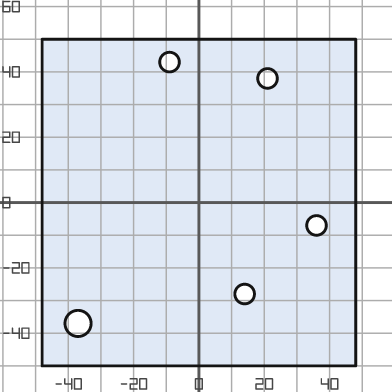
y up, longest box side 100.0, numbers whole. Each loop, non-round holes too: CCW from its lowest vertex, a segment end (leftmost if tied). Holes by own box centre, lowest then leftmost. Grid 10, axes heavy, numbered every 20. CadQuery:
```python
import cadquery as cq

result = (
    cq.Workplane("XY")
    .moveTo(-48.0, -50.0)
    .lineTo(48.0, -50.0)
    .lineTo(48.0, 50.0)
    .lineTo(-48.0, 50.0)
    .close()
    .moveTo(-37.0, -37.0)
    .circle(4.0)
    .moveTo(14.0, -28.0)
    .circle(3.0)
    .moveTo(36.0, -7.0)
    .circle(3.0)
    .moveTo(21.0, 38.0)
    .circle(3.0)
    .moveTo(-9.0, 43.0)
    .circle(3.0)
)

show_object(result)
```